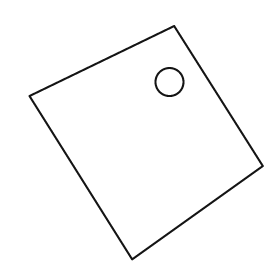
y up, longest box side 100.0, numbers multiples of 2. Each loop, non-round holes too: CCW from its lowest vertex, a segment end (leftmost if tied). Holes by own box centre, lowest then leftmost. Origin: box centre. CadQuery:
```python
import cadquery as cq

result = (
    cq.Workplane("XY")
    .moveTo(-6.0, -50.0)
    .lineTo(50.0, -10.0)
    .lineTo(12.0, 50.0)
    .lineTo(-50.0, 20.0)
    .close()
    .moveTo(10.0, 26.0)
    .circle(6.0)
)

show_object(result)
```